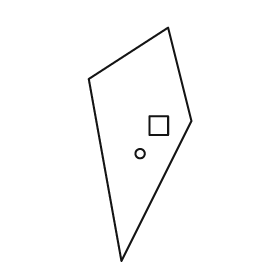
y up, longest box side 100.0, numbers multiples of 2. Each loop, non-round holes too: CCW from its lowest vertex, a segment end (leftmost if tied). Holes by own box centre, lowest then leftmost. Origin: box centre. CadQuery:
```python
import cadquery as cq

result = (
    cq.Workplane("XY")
    .moveTo(-8.0, -50.0)
    .lineTo(22.0, 10.0)
    .lineTo(12.0, 50.0)
    .lineTo(-22.0, 28.0)
    .close()
    .moveTo(0.0, -4.0)
    .circle(2.0)
    .moveTo(4.0, 4.0)
    .lineTo(12.0, 4.0)
    .lineTo(12.0, 12.0)
    .lineTo(4.0, 12.0)
    .close()
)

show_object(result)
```